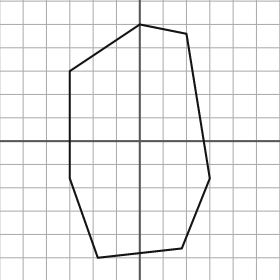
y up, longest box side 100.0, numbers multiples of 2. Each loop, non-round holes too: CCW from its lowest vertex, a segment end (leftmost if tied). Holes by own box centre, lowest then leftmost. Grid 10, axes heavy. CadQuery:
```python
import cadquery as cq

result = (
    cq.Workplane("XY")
    .moveTo(-18.0, -50.0)
    .lineTo(18.0, -46.0)
    .lineTo(30.0, -16.0)
    .lineTo(20.0, 46.0)
    .lineTo(0.0, 50.0)
    .lineTo(-30.0, 30.0)
    .lineTo(-30.0, -16.0)
    .close()
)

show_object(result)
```